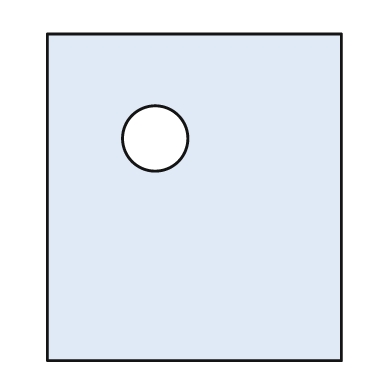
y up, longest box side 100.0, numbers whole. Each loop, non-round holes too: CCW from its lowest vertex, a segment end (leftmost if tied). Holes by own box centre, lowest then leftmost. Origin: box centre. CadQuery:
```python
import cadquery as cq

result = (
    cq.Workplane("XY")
    .moveTo(-45.0, -50.0)
    .lineTo(45.0, -50.0)
    .lineTo(45.0, 50.0)
    .lineTo(-45.0, 50.0)
    .close()
    .moveTo(-12.0, 18.0)
    .circle(10.0)
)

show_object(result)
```